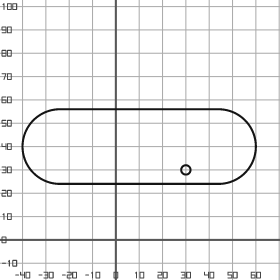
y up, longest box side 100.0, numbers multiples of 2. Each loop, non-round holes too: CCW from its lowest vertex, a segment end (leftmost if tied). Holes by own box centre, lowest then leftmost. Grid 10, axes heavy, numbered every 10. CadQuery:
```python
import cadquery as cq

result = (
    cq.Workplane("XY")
    .moveTo(-24.0, 24.0)
    .lineTo(44.0, 24.0)
    .threePointArc((60.0, 40.0), (44.0, 56.0))
    .lineTo(-24.0, 56.0)
    .threePointArc((-40.0, 40.0), (-24.0, 24.0))
    .close()
    .moveTo(30.0, 30.0)
    .circle(2.0)
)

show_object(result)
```